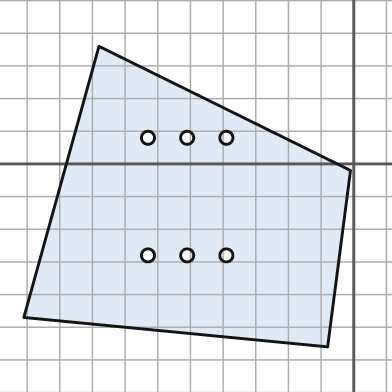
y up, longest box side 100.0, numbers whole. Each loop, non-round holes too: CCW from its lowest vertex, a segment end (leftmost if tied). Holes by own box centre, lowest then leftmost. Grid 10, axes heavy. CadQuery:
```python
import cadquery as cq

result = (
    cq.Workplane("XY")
    .moveTo(-8.0, -56.0)
    .lineTo(-1.0, -2.0)
    .lineTo(-78.0, 36.0)
    .lineTo(-101.0, -47.0)
    .close()
    .moveTo(-63.0, -28.0)
    .circle(2.0)
    .moveTo(-51.0, -28.0)
    .circle(2.0)
    .moveTo(-39.0, -28.0)
    .circle(2.0)
    .moveTo(-63.0, 8.0)
    .circle(2.0)
    .moveTo(-51.0, 8.0)
    .circle(2.0)
    .moveTo(-39.0, 8.0)
    .circle(2.0)
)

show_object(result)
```